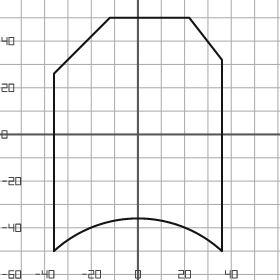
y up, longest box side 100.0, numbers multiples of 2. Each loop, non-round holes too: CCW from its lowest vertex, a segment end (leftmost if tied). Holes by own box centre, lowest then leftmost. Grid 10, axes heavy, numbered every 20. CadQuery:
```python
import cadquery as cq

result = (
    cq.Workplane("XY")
    .moveTo(-36.0, -50.0)
    .threePointArc((0.0, -36.0), (36.0, -50.0))
    .lineTo(36.0, 32.0)
    .lineTo(22.0, 50.0)
    .lineTo(-12.0, 50.0)
    .lineTo(-36.0, 26.0)
    .close()
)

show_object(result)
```